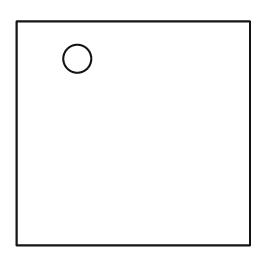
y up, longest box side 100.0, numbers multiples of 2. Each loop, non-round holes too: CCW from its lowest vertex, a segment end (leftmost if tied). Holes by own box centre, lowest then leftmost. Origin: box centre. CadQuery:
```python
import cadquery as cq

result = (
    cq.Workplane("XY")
    .moveTo(-50.0, -48.0)
    .lineTo(50.0, -48.0)
    .lineTo(50.0, 48.0)
    .lineTo(-50.0, 48.0)
    .close()
    .moveTo(-24.0, 32.0)
    .circle(6.0)
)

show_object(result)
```